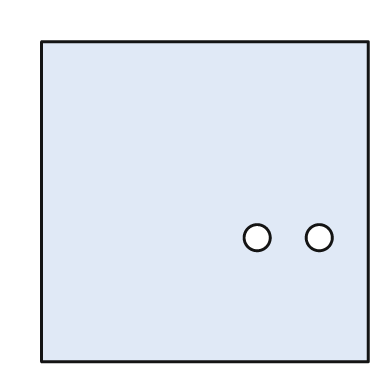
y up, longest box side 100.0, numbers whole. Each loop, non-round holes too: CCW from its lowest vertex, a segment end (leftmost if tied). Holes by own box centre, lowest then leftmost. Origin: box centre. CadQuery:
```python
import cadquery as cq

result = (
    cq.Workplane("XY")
    .moveTo(-50.0, -49.0)
    .lineTo(50.0, -49.0)
    .lineTo(50.0, 49.0)
    .lineTo(-50.0, 49.0)
    .close()
    .moveTo(16.0, -11.0)
    .circle(4.0)
    .moveTo(35.0, -11.0)
    .circle(4.0)
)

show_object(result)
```